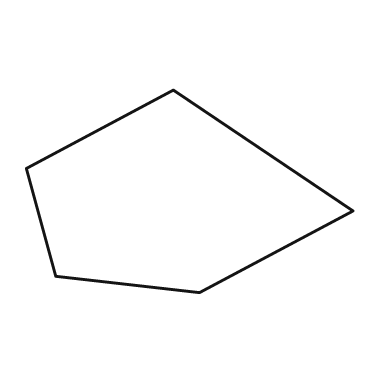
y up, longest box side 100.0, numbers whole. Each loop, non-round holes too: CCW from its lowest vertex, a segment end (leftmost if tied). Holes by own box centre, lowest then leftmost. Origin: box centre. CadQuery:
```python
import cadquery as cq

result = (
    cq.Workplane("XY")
    .moveTo(3.0, -31.0)
    .lineTo(50.0, -6.0)
    .lineTo(-5.0, 31.0)
    .lineTo(-50.0, 7.0)
    .lineTo(-41.0, -26.0)
    .close()
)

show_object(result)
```